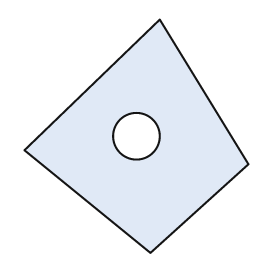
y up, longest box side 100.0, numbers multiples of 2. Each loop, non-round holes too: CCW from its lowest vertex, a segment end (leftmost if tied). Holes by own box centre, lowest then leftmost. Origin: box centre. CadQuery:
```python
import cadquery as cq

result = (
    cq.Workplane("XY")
    .moveTo(6.0, -50.0)
    .lineTo(48.0, -12.0)
    .lineTo(10.0, 50.0)
    .lineTo(-48.0, -6.0)
    .close()
    .moveTo(0.0, 0.0)
    .circle(10.0)
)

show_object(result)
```